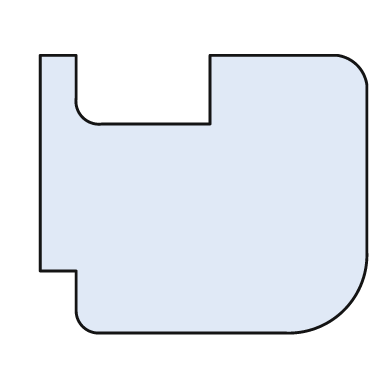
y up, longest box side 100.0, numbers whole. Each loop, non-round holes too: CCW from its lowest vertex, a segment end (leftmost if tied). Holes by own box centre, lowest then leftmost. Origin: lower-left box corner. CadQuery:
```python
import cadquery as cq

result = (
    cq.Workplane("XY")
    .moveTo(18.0, 0.0)
    .lineTo(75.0, 0.0)
    .threePointArc((93.0, 7.0), (100.0, 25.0))
    .lineTo(100.0, 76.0)
    .threePointArc((97.0, 82.0), (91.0, 85.0))
    .lineTo(52.0, 85.0)
    .lineTo(52.0, 64.0)
    .lineTo(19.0, 64.0)
    .threePointArc((13.0, 66.0), (11.0, 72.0))
    .lineTo(11.0, 85.0)
    .lineTo(0.0, 85.0)
    .lineTo(0.0, 19.0)
    .lineTo(11.0, 19.0)
    .lineTo(11.0, 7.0)
    .threePointArc((13.0, 2.0), (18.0, 0.0))
    .close()
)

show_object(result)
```